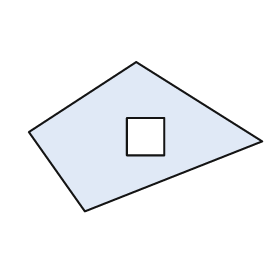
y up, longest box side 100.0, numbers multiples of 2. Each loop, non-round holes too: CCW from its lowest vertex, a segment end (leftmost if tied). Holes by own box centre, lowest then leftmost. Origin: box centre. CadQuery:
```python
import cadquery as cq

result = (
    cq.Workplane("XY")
    .moveTo(-26.0, -32.0)
    .lineTo(50.0, -2.0)
    .lineTo(-4.0, 32.0)
    .lineTo(-50.0, 2.0)
    .close()
    .moveTo(-8.0, -8.0)
    .lineTo(8.0, -8.0)
    .lineTo(8.0, 8.0)
    .lineTo(-8.0, 8.0)
    .close()
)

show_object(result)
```